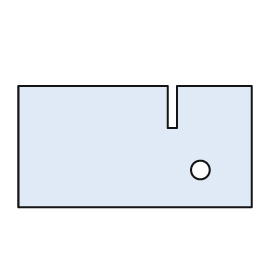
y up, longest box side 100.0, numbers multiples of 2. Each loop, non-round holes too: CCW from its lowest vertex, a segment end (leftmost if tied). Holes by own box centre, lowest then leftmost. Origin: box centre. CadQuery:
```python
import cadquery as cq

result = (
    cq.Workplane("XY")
    .moveTo(-50.0, -26.0)
    .lineTo(50.0, -26.0)
    .lineTo(50.0, 26.0)
    .lineTo(18.0, 26.0)
    .lineTo(18.0, 8.0)
    .lineTo(14.0, 8.0)
    .lineTo(14.0, 26.0)
    .lineTo(-50.0, 26.0)
    .close()
    .moveTo(28.0, -10.0)
    .circle(4.0)
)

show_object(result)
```